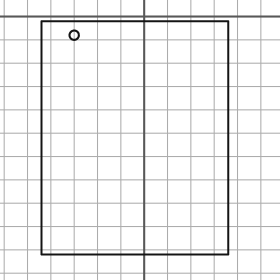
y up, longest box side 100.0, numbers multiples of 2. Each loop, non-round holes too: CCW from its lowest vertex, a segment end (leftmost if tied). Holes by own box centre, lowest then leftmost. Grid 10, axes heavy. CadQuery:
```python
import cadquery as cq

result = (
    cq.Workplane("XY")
    .moveTo(-44.0, -102.0)
    .lineTo(36.0, -102.0)
    .lineTo(36.0, -2.0)
    .lineTo(-44.0, -2.0)
    .close()
    .moveTo(-30.0, -8.0)
    .circle(2.0)
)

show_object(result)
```